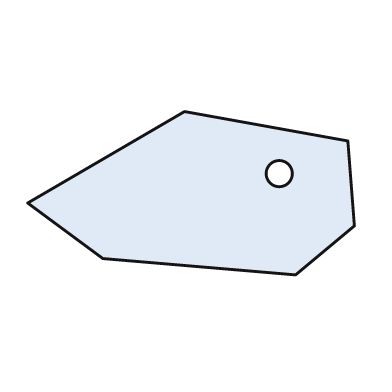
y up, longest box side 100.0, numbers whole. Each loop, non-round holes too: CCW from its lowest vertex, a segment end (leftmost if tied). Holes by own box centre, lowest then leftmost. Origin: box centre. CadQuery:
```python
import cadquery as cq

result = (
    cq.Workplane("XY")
    .moveTo(32.0, -25.0)
    .lineTo(50.0, -10.0)
    .lineTo(48.0, 16.0)
    .lineTo(-2.0, 25.0)
    .lineTo(-50.0, -3.0)
    .lineTo(-27.0, -20.0)
    .close()
    .moveTo(27.0, 6.0)
    .circle(4.0)
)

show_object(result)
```